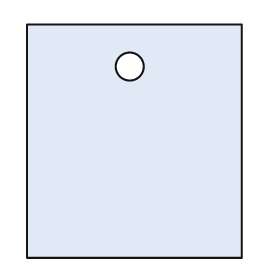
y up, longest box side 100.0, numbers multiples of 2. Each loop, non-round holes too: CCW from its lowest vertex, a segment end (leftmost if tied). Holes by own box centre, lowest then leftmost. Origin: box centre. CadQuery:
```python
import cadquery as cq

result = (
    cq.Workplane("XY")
    .moveTo(-46.0, -50.0)
    .lineTo(46.0, -50.0)
    .lineTo(46.0, 50.0)
    .lineTo(-46.0, 50.0)
    .close()
    .moveTo(-2.0, 32.0)
    .circle(6.0)
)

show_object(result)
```